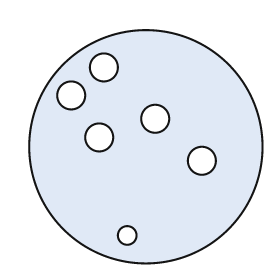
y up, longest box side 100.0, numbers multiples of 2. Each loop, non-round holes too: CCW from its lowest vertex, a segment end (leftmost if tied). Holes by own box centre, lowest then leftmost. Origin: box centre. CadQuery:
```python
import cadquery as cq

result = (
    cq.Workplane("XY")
    .moveTo(0.0, 0.0)
    .circle(50.0)
    .moveTo(-8.0, -38.0)
    .circle(4.0)
    .moveTo(24.0, -6.0)
    .circle(6.0)
    .moveTo(-20.0, 4.0)
    .circle(6.0)
    .moveTo(4.0, 12.0)
    .circle(6.0)
    .moveTo(-32.0, 22.0)
    .circle(6.0)
    .moveTo(-18.0, 34.0)
    .circle(6.0)
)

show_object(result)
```